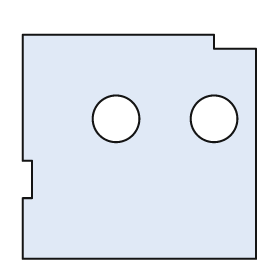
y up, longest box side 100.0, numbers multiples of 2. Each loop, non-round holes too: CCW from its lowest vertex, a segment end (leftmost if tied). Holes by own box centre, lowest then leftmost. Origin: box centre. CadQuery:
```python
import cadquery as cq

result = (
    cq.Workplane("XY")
    .moveTo(-50.0, -48.0)
    .lineTo(50.0, -48.0)
    .lineTo(50.0, 42.0)
    .lineTo(32.0, 42.0)
    .lineTo(32.0, 48.0)
    .lineTo(-50.0, 48.0)
    .lineTo(-50.0, -6.0)
    .lineTo(-46.0, -6.0)
    .lineTo(-46.0, -22.0)
    .lineTo(-50.0, -22.0)
    .close()
    .moveTo(-10.0, 12.0)
    .circle(10.0)
    .moveTo(32.0, 12.0)
    .circle(10.0)
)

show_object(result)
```